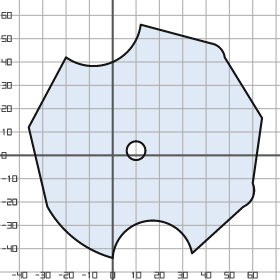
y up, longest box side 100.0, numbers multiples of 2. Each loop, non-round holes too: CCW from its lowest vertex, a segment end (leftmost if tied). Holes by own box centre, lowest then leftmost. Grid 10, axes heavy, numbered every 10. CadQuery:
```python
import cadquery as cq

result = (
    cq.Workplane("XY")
    .moveTo(0.0, -44.0)
    .threePointArc((16.0, -28.0), (34.0, -42.0))
    .lineTo(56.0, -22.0)
    .threePointArc((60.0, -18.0), (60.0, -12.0))
    .lineTo(64.0, 16.0)
    .lineTo(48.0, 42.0)
    .threePointArc((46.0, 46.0), (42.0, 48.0))
    .lineTo(12.0, 56.0)
    .threePointArc((0.0, 40.0), (-20.0, 42.0))
    .lineTo(-36.0, 12.0)
    .lineTo(-28.0, -22.0)
    .threePointArc((-16.0, -36.0), (0.0, -44.0))
    .close()
    .moveTo(10.0, 2.0)
    .circle(4.0)
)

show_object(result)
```